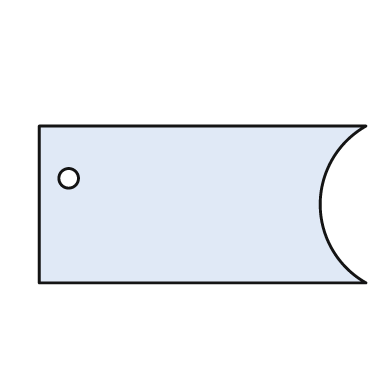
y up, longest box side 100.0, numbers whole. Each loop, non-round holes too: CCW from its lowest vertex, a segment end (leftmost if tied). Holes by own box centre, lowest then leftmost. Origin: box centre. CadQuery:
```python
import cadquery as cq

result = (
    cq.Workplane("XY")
    .moveTo(-50.0, -24.0)
    .lineTo(50.0, -24.0)
    .threePointArc((36.0, 0.0), (50.0, 24.0))
    .lineTo(-50.0, 24.0)
    .close()
    .moveTo(-41.0, 8.0)
    .circle(3.0)
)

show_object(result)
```